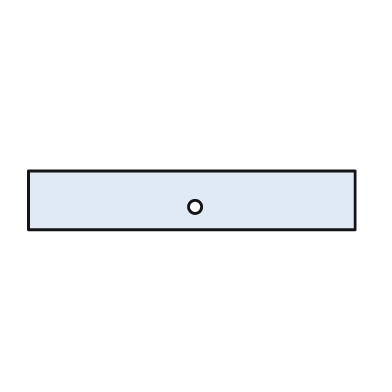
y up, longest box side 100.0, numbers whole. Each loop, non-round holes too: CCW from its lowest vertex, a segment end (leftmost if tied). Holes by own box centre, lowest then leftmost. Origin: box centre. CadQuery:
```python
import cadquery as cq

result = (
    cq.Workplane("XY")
    .moveTo(-50.0, -9.0)
    .lineTo(50.0, -9.0)
    .lineTo(50.0, 9.0)
    .lineTo(-50.0, 9.0)
    .close()
    .moveTo(1.0, -2.0)
    .circle(2.0)
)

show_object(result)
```